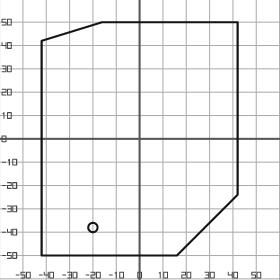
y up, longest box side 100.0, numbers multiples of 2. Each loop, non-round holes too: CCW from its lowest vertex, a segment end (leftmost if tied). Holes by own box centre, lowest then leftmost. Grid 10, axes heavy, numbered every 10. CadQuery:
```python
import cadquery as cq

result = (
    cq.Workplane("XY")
    .moveTo(-42.0, -50.0)
    .lineTo(16.0, -50.0)
    .lineTo(42.0, -24.0)
    .lineTo(42.0, 50.0)
    .lineTo(-16.0, 50.0)
    .lineTo(-42.0, 42.0)
    .close()
    .moveTo(-20.0, -38.0)
    .circle(2.0)
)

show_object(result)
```